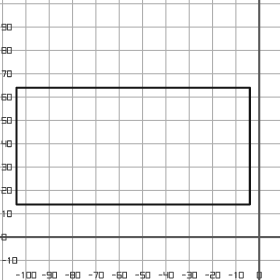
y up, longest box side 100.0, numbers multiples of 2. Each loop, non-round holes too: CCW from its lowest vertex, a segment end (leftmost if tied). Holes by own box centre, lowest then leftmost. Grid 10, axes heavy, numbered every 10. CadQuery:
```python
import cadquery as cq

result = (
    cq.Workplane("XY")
    .moveTo(-104.0, 14.0)
    .lineTo(-4.0, 14.0)
    .lineTo(-4.0, 64.0)
    .lineTo(-104.0, 64.0)
    .close()
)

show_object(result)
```